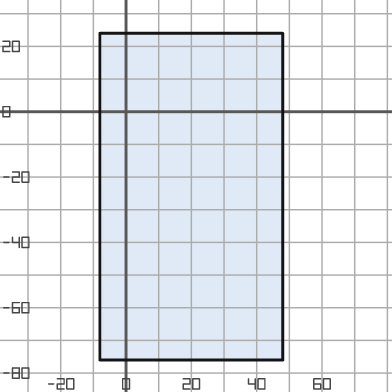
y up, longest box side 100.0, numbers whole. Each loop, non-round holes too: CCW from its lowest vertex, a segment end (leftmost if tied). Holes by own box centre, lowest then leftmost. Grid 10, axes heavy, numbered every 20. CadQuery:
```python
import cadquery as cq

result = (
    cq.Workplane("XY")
    .moveTo(-8.0, -76.0)
    .lineTo(48.0, -76.0)
    .lineTo(48.0, 24.0)
    .lineTo(-8.0, 24.0)
    .close()
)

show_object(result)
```